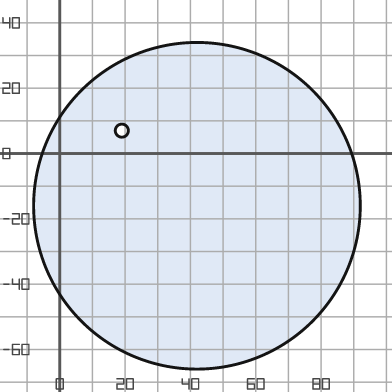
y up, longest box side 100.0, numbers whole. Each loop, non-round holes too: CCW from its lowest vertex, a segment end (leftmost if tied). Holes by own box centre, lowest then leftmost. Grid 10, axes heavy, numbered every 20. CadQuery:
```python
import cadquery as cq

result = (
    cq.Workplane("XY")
    .moveTo(42.0, -16.0)
    .circle(50.0)
    .moveTo(19.0, 7.0)
    .circle(2.0)
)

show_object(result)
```